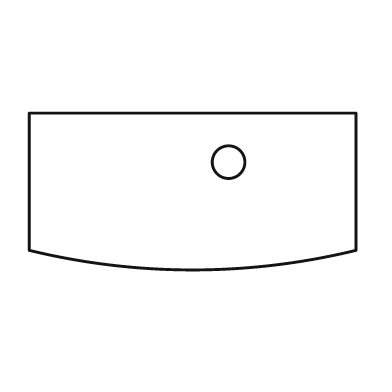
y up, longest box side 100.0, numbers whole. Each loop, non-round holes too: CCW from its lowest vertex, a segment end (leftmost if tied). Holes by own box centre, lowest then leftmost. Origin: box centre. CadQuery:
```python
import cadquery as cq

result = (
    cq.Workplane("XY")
    .moveTo(-50.0, -18.0)
    .threePointArc((0.0, -24.0), (50.0, -18.0))
    .lineTo(50.0, 24.0)
    .lineTo(-50.0, 24.0)
    .close()
    .moveTo(11.0, 9.0)
    .circle(5.0)
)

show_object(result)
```